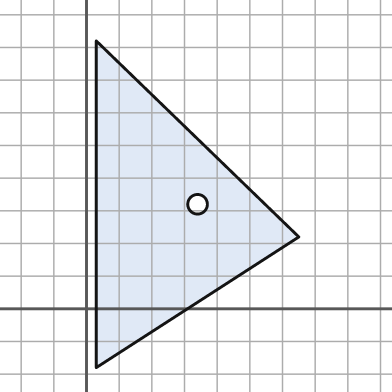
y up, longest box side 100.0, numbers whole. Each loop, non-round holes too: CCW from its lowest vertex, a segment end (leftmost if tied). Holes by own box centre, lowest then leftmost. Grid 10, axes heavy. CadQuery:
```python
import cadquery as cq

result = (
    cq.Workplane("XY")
    .moveTo(3.0, -18.0)
    .lineTo(65.0, 22.0)
    .lineTo(3.0, 82.0)
    .close()
    .moveTo(34.0, 32.0)
    .circle(3.0)
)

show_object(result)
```